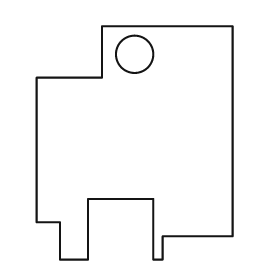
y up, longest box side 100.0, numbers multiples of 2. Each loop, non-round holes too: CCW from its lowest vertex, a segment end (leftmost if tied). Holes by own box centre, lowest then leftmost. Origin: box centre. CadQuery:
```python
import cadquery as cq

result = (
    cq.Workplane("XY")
    .moveTo(-32.0, -50.0)
    .lineTo(-20.0, -50.0)
    .lineTo(-20.0, -24.0)
    .lineTo(8.0, -24.0)
    .lineTo(8.0, -50.0)
    .lineTo(12.0, -50.0)
    .lineTo(12.0, -40.0)
    .lineTo(42.0, -40.0)
    .lineTo(42.0, 50.0)
    .lineTo(-14.0, 50.0)
    .lineTo(-14.0, 28.0)
    .lineTo(-42.0, 28.0)
    .lineTo(-42.0, -34.0)
    .lineTo(-32.0, -34.0)
    .close()
    .moveTo(0.0, 38.0)
    .circle(8.0)
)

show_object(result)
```